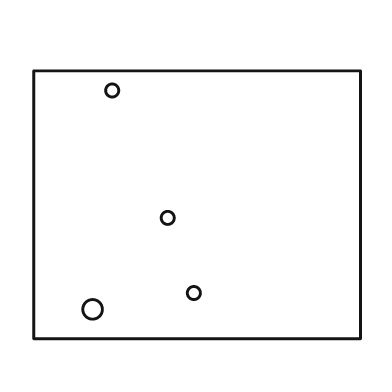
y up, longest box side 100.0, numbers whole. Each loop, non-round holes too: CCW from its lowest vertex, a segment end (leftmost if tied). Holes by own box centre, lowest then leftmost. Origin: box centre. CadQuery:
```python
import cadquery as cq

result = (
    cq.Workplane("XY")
    .moveTo(-50.0, -41.0)
    .lineTo(50.0, -41.0)
    .lineTo(50.0, 41.0)
    .lineTo(-50.0, 41.0)
    .close()
    .moveTo(-32.0, -32.0)
    .circle(3.0)
    .moveTo(-1.0, -27.0)
    .circle(2.0)
    .moveTo(-9.0, -4.0)
    .circle(2.0)
    .moveTo(-26.0, 35.0)
    .circle(2.0)
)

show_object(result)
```